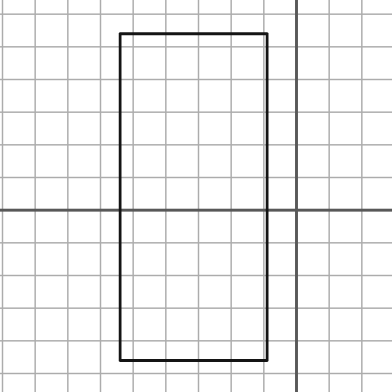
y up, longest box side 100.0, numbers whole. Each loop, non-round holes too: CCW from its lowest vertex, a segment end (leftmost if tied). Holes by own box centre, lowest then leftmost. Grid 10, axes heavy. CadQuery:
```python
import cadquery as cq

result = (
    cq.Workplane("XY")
    .moveTo(-54.0, -46.0)
    .lineTo(-9.0, -46.0)
    .lineTo(-9.0, 54.0)
    .lineTo(-54.0, 54.0)
    .close()
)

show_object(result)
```